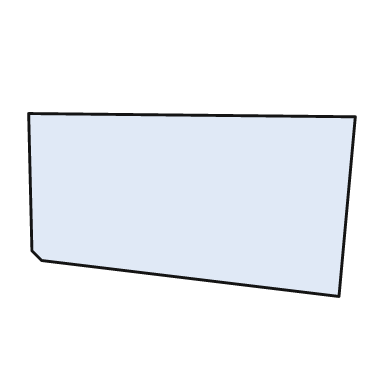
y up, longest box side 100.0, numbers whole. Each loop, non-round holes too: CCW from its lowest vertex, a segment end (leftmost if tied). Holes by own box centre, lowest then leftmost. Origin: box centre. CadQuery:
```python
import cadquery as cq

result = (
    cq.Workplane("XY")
    .moveTo(45.0, -28.0)
    .lineTo(50.0, 27.0)
    .lineTo(-50.0, 28.0)
    .lineTo(-49.0, -14.0)
    .lineTo(-46.0, -17.0)
    .close()
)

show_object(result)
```